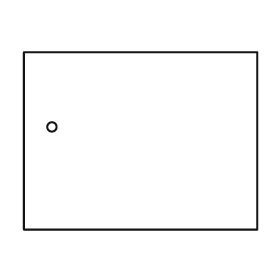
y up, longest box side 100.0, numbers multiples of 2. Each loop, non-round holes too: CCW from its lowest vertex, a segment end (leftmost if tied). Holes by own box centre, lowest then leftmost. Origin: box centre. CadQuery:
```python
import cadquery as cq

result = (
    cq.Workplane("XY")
    .moveTo(-50.0, -38.0)
    .lineTo(50.0, -38.0)
    .lineTo(50.0, 38.0)
    .lineTo(-50.0, 38.0)
    .close()
    .moveTo(-38.0, 6.0)
    .circle(2.0)
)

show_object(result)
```